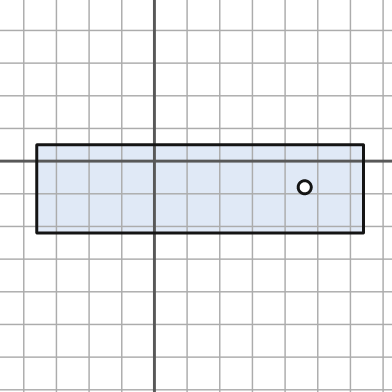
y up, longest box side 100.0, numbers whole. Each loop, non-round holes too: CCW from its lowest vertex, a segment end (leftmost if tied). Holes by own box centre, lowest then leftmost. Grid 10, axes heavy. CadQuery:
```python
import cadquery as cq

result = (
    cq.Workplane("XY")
    .moveTo(-36.0, -22.0)
    .lineTo(64.0, -22.0)
    .lineTo(64.0, 5.0)
    .lineTo(-36.0, 5.0)
    .close()
    .moveTo(46.0, -8.0)
    .circle(2.0)
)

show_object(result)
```